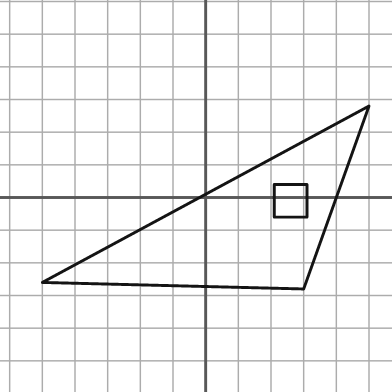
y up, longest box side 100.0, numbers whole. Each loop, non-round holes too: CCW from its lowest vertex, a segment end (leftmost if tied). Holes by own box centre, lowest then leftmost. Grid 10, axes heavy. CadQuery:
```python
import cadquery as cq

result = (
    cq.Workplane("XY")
    .moveTo(30.0, -28.0)
    .lineTo(50.0, 28.0)
    .lineTo(-50.0, -26.0)
    .close()
    .moveTo(21.0, -6.0)
    .lineTo(31.0, -6.0)
    .lineTo(31.0, 4.0)
    .lineTo(21.0, 4.0)
    .close()
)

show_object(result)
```